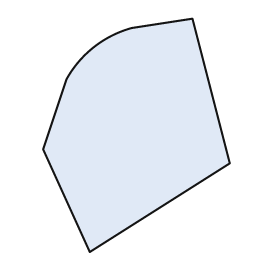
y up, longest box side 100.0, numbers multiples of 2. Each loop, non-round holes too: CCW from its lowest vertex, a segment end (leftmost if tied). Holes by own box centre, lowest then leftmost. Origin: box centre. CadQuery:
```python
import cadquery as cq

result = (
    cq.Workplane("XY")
    .moveTo(-20.0, -50.0)
    .lineTo(40.0, -12.0)
    .lineTo(24.0, 50.0)
    .lineTo(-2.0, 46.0)
    .threePointArc((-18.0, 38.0), (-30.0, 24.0))
    .lineTo(-40.0, -6.0)
    .close()
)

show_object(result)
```